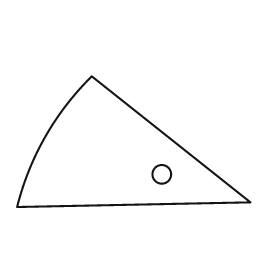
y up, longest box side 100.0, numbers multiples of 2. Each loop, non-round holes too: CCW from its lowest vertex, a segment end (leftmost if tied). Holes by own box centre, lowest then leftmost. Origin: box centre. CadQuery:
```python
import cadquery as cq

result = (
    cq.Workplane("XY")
    .moveTo(-50.0, -28.0)
    .lineTo(50.0, -26.0)
    .lineTo(-18.0, 28.0)
    .threePointArc((-38.0, 2.0), (-50.0, -28.0))
    .close()
    .moveTo(12.0, -14.0)
    .circle(4.0)
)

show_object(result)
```